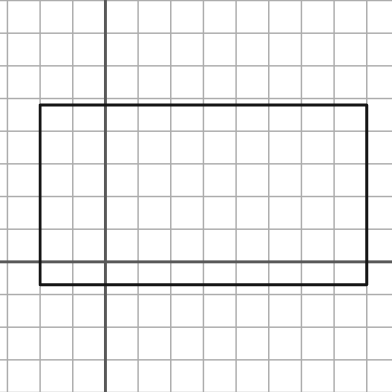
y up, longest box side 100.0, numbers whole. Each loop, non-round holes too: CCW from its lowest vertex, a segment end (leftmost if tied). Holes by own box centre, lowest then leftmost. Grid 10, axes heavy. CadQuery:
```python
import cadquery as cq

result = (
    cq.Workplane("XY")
    .moveTo(-20.0, -7.0)
    .lineTo(80.0, -7.0)
    .lineTo(80.0, 48.0)
    .lineTo(-20.0, 48.0)
    .close()
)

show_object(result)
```